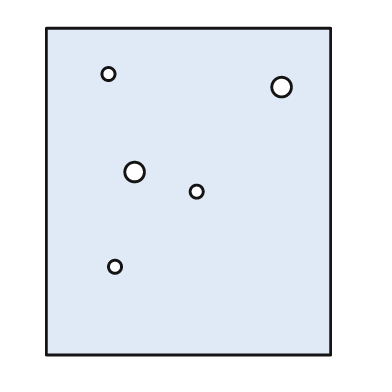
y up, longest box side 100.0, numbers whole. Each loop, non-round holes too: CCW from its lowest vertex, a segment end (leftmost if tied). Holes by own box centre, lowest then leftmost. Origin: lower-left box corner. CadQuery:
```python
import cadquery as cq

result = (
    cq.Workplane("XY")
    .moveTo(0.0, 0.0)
    .lineTo(87.0, 0.0)
    .lineTo(87.0, 100.0)
    .lineTo(0.0, 100.0)
    .close()
    .moveTo(21.0, 27.0)
    .circle(2.0)
    .moveTo(46.0, 50.0)
    .circle(2.0)
    .moveTo(27.0, 56.0)
    .circle(3.0)
    .moveTo(72.0, 82.0)
    .circle(3.0)
    .moveTo(19.0, 86.0)
    .circle(2.0)
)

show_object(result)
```